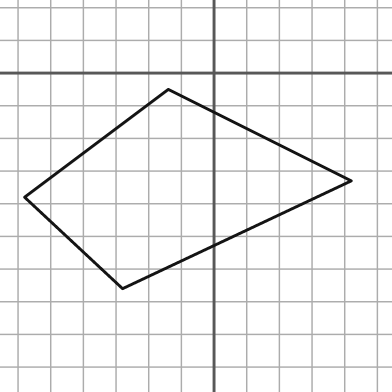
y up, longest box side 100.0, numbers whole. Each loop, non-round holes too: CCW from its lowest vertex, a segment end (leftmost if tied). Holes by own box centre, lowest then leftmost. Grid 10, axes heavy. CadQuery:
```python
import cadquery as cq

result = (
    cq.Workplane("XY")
    .moveTo(-28.0, -66.0)
    .lineTo(42.0, -33.0)
    .lineTo(-14.0, -5.0)
    .lineTo(-58.0, -38.0)
    .close()
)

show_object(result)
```